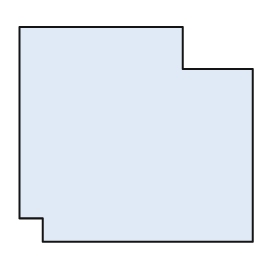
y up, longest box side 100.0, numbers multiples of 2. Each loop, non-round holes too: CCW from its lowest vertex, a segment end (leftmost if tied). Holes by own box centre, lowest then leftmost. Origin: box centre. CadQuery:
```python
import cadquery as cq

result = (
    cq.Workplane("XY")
    .moveTo(-40.0, -46.0)
    .lineTo(50.0, -46.0)
    .lineTo(50.0, 28.0)
    .lineTo(20.0, 28.0)
    .lineTo(20.0, 46.0)
    .lineTo(-50.0, 46.0)
    .lineTo(-50.0, -36.0)
    .lineTo(-40.0, -36.0)
    .close()
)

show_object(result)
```